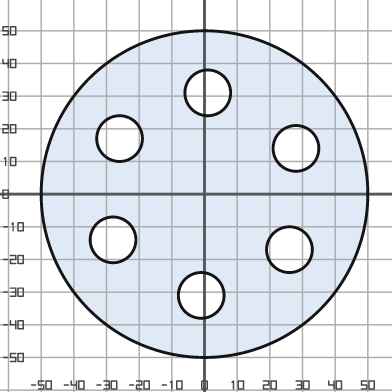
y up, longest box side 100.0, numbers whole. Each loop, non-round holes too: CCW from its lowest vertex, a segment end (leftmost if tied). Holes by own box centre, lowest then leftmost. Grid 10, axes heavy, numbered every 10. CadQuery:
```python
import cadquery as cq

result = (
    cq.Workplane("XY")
    .moveTo(0.0, 0.0)
    .circle(50.0)
    .moveTo(-1.0, -31.0)
    .circle(7.0)
    .moveTo(26.0, -17.0)
    .circle(7.0)
    .moveTo(-28.0, -14.0)
    .circle(7.0)
    .moveTo(28.0, 14.0)
    .circle(7.0)
    .moveTo(-26.0, 17.0)
    .circle(7.0)
    .moveTo(1.0, 31.0)
    .circle(7.0)
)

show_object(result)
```